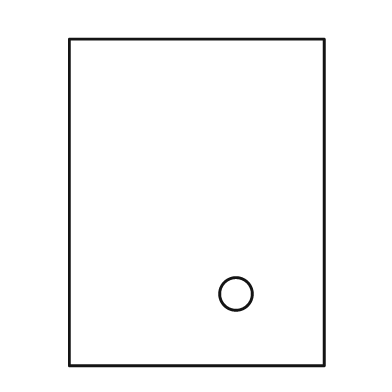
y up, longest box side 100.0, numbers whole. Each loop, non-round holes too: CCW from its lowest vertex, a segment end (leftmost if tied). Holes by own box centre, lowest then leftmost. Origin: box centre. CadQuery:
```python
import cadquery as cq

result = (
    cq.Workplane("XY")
    .moveTo(-39.0, -50.0)
    .lineTo(39.0, -50.0)
    .lineTo(39.0, 50.0)
    .lineTo(-39.0, 50.0)
    .close()
    .moveTo(12.0, -28.0)
    .circle(5.0)
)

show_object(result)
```